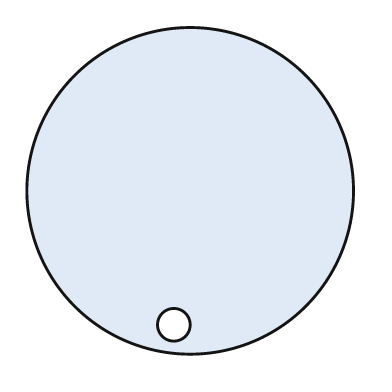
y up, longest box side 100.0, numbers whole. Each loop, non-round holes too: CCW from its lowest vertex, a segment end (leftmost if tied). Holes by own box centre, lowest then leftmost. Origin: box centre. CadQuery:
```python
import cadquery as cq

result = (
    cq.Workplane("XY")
    .moveTo(0.0, 0.0)
    .circle(50.0)
    .moveTo(-5.0, -41.0)
    .circle(5.0)
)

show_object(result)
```